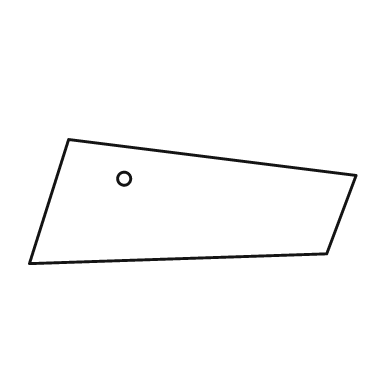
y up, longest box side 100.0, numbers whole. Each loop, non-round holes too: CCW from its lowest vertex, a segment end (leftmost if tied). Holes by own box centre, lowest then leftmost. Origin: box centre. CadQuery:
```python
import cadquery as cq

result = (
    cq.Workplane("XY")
    .moveTo(-50.0, -19.0)
    .lineTo(41.0, -16.0)
    .lineTo(50.0, 8.0)
    .lineTo(-38.0, 19.0)
    .close()
    .moveTo(-21.0, 7.0)
    .circle(2.0)
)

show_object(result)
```